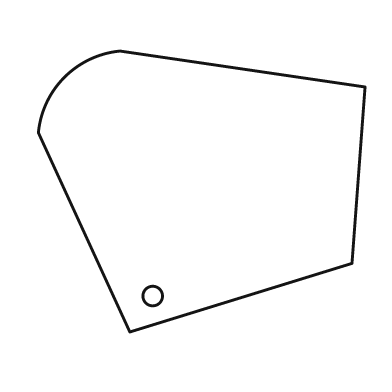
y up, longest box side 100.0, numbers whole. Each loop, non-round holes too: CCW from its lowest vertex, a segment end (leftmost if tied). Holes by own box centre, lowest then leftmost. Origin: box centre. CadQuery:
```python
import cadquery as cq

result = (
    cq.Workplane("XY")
    .moveTo(-22.0, -43.0)
    .lineTo(46.0, -22.0)
    .lineTo(50.0, 32.0)
    .lineTo(-25.0, 43.0)
    .threePointArc((-42.0, 35.0), (-50.0, 18.0))
    .close()
    .moveTo(-15.0, -32.0)
    .circle(3.0)
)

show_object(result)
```